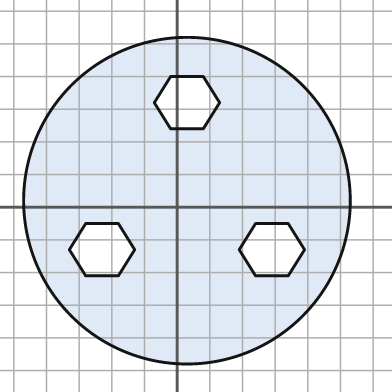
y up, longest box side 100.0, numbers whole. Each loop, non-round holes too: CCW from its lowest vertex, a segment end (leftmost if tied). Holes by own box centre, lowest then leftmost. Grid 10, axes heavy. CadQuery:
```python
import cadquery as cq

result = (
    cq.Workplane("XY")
    .moveTo(3.0, 2.0)
    .circle(50.0)
    .moveTo(-28.0, -21.0)
    .lineTo(-18.0, -21.0)
    .lineTo(-13.0, -13.0)
    .lineTo(-18.0, -5.0)
    .lineTo(-28.0, -5.0)
    .lineTo(-33.0, -13.0)
    .close()
    .moveTo(24.0, -21.0)
    .lineTo(34.0, -21.0)
    .lineTo(39.0, -13.0)
    .lineTo(34.0, -5.0)
    .lineTo(24.0, -5.0)
    .lineTo(19.0, -13.0)
    .close()
    .moveTo(-2.0, 24.0)
    .lineTo(8.0, 24.0)
    .lineTo(13.0, 32.0)
    .lineTo(8.0, 40.0)
    .lineTo(-2.0, 40.0)
    .lineTo(-7.0, 32.0)
    .close()
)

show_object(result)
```